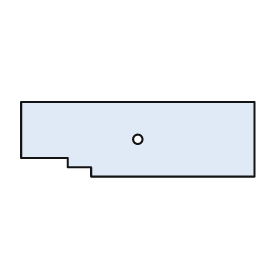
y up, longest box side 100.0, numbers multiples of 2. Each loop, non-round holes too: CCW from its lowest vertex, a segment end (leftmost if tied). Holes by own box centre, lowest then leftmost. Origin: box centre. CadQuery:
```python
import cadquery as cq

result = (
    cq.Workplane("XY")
    .moveTo(-20.0, -16.0)
    .lineTo(50.0, -16.0)
    .lineTo(50.0, 16.0)
    .lineTo(-50.0, 16.0)
    .lineTo(-50.0, -8.0)
    .lineTo(-30.0, -8.0)
    .lineTo(-30.0, -12.0)
    .lineTo(-20.0, -12.0)
    .close()
    .moveTo(0.0, 0.0)
    .circle(2.0)
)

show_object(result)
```